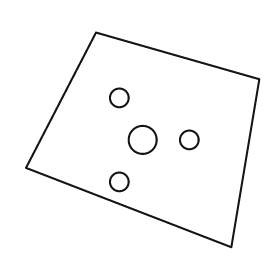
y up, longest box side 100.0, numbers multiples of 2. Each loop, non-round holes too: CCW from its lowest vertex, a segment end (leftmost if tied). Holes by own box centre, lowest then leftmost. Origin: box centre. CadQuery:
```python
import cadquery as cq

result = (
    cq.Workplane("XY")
    .moveTo(38.0, -46.0)
    .lineTo(50.0, 26.0)
    .lineTo(-20.0, 46.0)
    .lineTo(-50.0, -12.0)
    .close()
    .moveTo(-10.0, -18.0)
    .circle(4.0)
    .moveTo(0.0, 0.0)
    .circle(6.0)
    .moveTo(20.0, 0.0)
    .circle(4.0)
    .moveTo(-10.0, 18.0)
    .circle(4.0)
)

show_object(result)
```